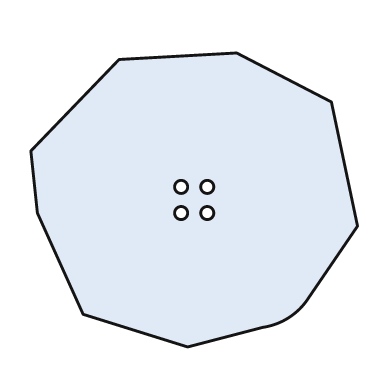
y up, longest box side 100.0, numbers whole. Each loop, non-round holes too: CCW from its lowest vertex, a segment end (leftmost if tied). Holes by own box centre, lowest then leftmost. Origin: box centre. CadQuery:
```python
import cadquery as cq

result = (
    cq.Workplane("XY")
    .moveTo(-2.0, -45.0)
    .lineTo(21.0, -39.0)
    .threePointArc((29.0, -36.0), (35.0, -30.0))
    .lineTo(50.0, -8.0)
    .lineTo(42.0, 30.0)
    .lineTo(13.0, 45.0)
    .lineTo(-23.0, 43.0)
    .lineTo(-50.0, 15.0)
    .lineTo(-48.0, -4.0)
    .lineTo(-34.0, -35.0)
    .close()
    .moveTo(-4.0, -4.0)
    .circle(2.0)
    .moveTo(4.0, -4.0)
    .circle(2.0)
    .moveTo(-4.0, 4.0)
    .circle(2.0)
    .moveTo(4.0, 4.0)
    .circle(2.0)
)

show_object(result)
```